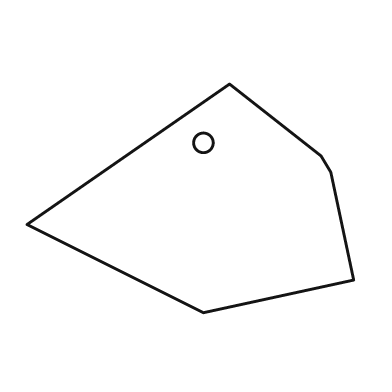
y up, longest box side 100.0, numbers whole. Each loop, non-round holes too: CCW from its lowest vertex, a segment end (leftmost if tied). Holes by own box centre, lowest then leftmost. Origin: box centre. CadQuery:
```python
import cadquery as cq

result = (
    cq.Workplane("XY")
    .moveTo(4.0, -35.0)
    .lineTo(50.0, -25.0)
    .lineTo(43.0, 8.0)
    .lineTo(40.0, 13.0)
    .lineTo(12.0, 35.0)
    .lineTo(-50.0, -8.0)
    .close()
    .moveTo(4.0, 17.0)
    .circle(3.0)
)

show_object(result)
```